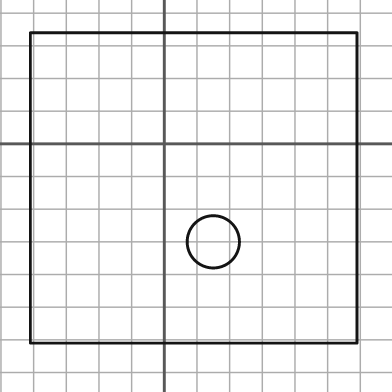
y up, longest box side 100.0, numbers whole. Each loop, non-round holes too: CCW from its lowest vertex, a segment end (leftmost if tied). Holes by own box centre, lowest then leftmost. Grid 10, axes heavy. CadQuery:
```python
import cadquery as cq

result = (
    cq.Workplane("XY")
    .moveTo(-41.0, -61.0)
    .lineTo(59.0, -61.0)
    .lineTo(59.0, 34.0)
    .lineTo(-41.0, 34.0)
    .close()
    .moveTo(15.0, -30.0)
    .circle(8.0)
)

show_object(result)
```